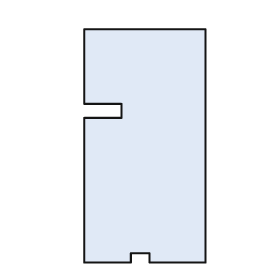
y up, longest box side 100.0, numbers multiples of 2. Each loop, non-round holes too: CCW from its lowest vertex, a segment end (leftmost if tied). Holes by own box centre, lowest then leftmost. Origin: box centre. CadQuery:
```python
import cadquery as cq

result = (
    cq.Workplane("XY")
    .moveTo(-26.0, -50.0)
    .lineTo(-6.0, -50.0)
    .lineTo(-6.0, -46.0)
    .lineTo(2.0, -46.0)
    .lineTo(2.0, -50.0)
    .lineTo(26.0, -50.0)
    .lineTo(26.0, 50.0)
    .lineTo(-26.0, 50.0)
    .lineTo(-26.0, 18.0)
    .lineTo(-10.0, 18.0)
    .lineTo(-10.0, 12.0)
    .lineTo(-26.0, 12.0)
    .close()
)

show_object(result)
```